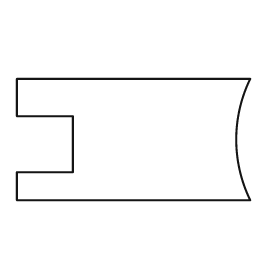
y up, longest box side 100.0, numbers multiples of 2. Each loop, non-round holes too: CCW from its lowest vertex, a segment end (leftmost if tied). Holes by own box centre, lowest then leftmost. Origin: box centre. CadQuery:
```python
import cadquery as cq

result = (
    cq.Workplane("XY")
    .moveTo(-50.0, -26.0)
    .lineTo(50.0, -26.0)
    .threePointArc((44.0, 0.0), (50.0, 26.0))
    .lineTo(-50.0, 26.0)
    .lineTo(-50.0, 10.0)
    .lineTo(-26.0, 10.0)
    .lineTo(-26.0, -14.0)
    .lineTo(-50.0, -14.0)
    .close()
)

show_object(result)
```